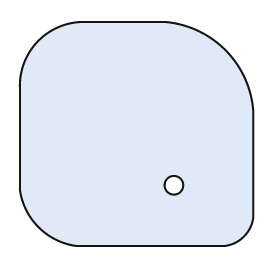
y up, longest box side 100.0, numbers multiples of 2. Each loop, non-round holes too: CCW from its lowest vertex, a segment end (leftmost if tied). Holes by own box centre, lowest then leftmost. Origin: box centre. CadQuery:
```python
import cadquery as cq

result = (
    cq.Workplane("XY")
    .moveTo(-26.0, -48.0)
    .lineTo(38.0, -48.0)
    .threePointArc((46.0, -44.0), (50.0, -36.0))
    .lineTo(50.0, 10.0)
    .threePointArc((38.0, 36.0), (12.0, 48.0))
    .lineTo(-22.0, 48.0)
    .threePointArc((-42.0, 40.0), (-50.0, 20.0))
    .lineTo(-50.0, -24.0)
    .threePointArc((-42.0, -40.0), (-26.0, -48.0))
    .close()
    .moveTo(16.0, -22.0)
    .circle(4.0)
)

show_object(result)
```